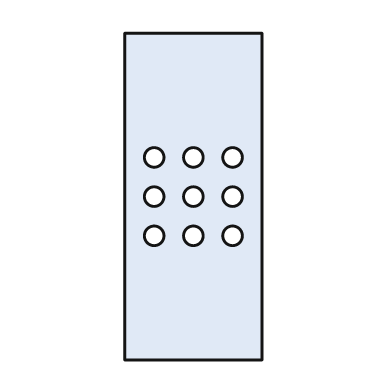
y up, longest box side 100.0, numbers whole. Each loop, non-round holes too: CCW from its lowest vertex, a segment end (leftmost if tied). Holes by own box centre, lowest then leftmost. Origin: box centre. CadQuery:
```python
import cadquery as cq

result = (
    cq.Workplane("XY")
    .moveTo(-21.0, -50.0)
    .lineTo(21.0, -50.0)
    .lineTo(21.0, 50.0)
    .lineTo(-21.0, 50.0)
    .close()
    .moveTo(-12.0, -12.0)
    .circle(3.0)
    .moveTo(0.0, -12.0)
    .circle(3.0)
    .moveTo(12.0, -12.0)
    .circle(3.0)
    .moveTo(-12.0, 0.0)
    .circle(3.0)
    .moveTo(0.0, 0.0)
    .circle(3.0)
    .moveTo(12.0, 0.0)
    .circle(3.0)
    .moveTo(-12.0, 12.0)
    .circle(3.0)
    .moveTo(0.0, 12.0)
    .circle(3.0)
    .moveTo(12.0, 12.0)
    .circle(3.0)
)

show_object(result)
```